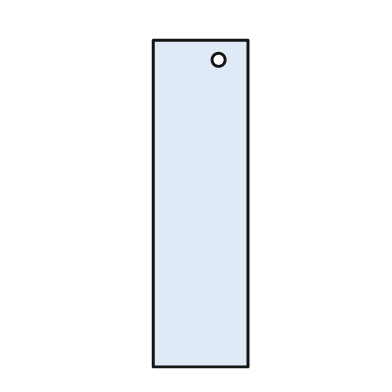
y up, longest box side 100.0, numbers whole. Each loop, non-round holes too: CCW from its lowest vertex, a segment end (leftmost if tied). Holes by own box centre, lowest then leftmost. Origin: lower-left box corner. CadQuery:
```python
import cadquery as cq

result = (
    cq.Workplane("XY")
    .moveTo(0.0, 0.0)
    .lineTo(29.0, 0.0)
    .lineTo(29.0, 100.0)
    .lineTo(0.0, 100.0)
    .close()
    .moveTo(20.0, 94.0)
    .circle(2.0)
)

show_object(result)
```